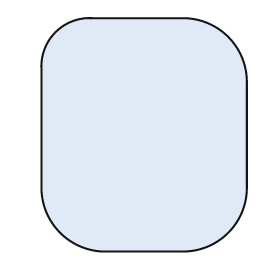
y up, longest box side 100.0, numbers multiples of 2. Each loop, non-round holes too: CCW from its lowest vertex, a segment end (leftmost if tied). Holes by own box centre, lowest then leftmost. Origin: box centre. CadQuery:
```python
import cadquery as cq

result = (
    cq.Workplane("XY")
    .moveTo(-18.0, -50.0)
    .lineTo(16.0, -50.0)
    .threePointArc((36.0, -42.0), (44.0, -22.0))
    .lineTo(44.0, 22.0)
    .threePointArc((36.0, 42.0), (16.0, 50.0))
    .lineTo(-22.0, 50.0)
    .threePointArc((-38.0, 44.0), (-44.0, 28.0))
    .lineTo(-44.0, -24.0)
    .threePointArc((-36.0, -42.0), (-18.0, -50.0))
    .close()
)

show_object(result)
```